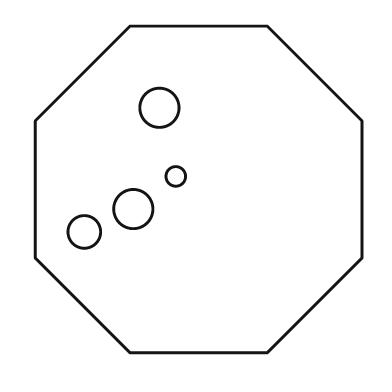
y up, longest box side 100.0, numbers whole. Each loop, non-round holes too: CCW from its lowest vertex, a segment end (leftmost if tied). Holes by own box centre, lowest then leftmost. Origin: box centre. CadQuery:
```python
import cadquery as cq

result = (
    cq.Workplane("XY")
    .moveTo(-21.0, -50.0)
    .lineTo(21.0, -50.0)
    .lineTo(50.0, -21.0)
    .lineTo(50.0, 21.0)
    .lineTo(21.0, 50.0)
    .lineTo(-21.0, 50.0)
    .lineTo(-50.0, 21.0)
    .lineTo(-50.0, -21.0)
    .close()
    .moveTo(-35.0, -13.0)
    .circle(5.0)
    .moveTo(-20.0, -6.0)
    .circle(6.0)
    .moveTo(-7.0, 4.0)
    .circle(3.0)
    .moveTo(-12.0, 25.0)
    .circle(6.0)
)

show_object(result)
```